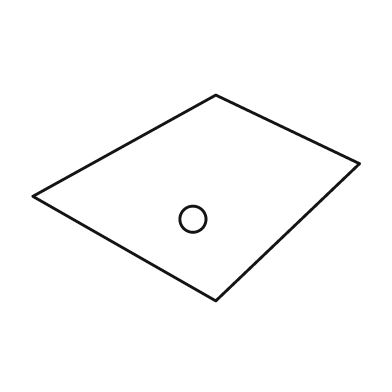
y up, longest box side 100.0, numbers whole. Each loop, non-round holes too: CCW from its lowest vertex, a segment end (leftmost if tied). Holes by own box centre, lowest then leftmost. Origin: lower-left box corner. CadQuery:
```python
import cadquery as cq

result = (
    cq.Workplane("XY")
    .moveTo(56.0, 0.0)
    .lineTo(100.0, 42.0)
    .lineTo(56.0, 63.0)
    .lineTo(0.0, 32.0)
    .close()
    .moveTo(49.0, 25.0)
    .circle(4.0)
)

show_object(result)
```